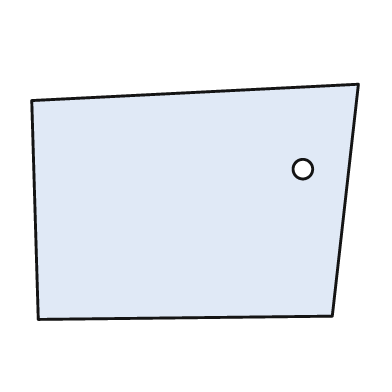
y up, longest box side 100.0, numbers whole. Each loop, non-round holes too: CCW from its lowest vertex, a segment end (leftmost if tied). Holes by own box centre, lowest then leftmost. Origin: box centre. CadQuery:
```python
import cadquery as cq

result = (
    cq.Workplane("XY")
    .moveTo(-48.0, -36.0)
    .lineTo(42.0, -35.0)
    .lineTo(50.0, 36.0)
    .lineTo(-50.0, 31.0)
    .close()
    .moveTo(33.0, 10.0)
    .circle(3.0)
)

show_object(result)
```